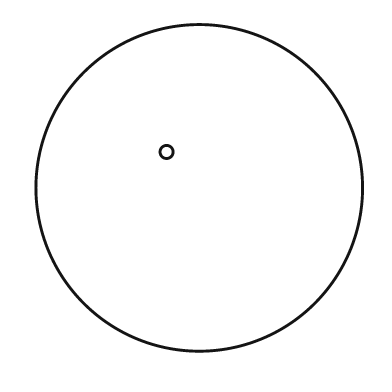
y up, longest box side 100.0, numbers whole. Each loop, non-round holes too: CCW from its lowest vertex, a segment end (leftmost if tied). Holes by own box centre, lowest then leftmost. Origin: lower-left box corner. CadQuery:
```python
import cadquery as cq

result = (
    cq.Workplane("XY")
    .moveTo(50.0, 50.0)
    .circle(50.0)
    .moveTo(40.0, 61.0)
    .circle(2.0)
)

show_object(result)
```